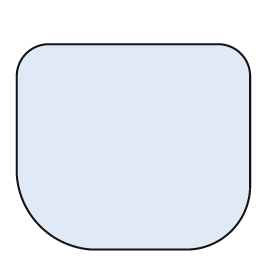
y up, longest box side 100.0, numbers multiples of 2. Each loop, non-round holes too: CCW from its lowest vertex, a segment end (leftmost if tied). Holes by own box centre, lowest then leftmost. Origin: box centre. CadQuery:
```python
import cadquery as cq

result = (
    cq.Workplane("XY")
    .moveTo(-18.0, -44.0)
    .lineTo(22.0, -44.0)
    .threePointArc((42.0, -36.0), (50.0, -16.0))
    .lineTo(50.0, 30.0)
    .threePointArc((46.0, 40.0), (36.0, 44.0))
    .lineTo(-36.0, 44.0)
    .threePointArc((-46.0, 40.0), (-50.0, 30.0))
    .lineTo(-50.0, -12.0)
    .threePointArc((-40.0, -34.0), (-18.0, -44.0))
    .close()
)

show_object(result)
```